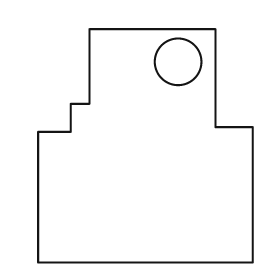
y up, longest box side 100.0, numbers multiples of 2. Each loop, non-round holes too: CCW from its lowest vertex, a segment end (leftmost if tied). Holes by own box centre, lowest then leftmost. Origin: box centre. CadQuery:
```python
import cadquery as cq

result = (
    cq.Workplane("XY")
    .moveTo(-46.0, -50.0)
    .lineTo(46.0, -50.0)
    .lineTo(46.0, 8.0)
    .lineTo(30.0, 8.0)
    .lineTo(30.0, 50.0)
    .lineTo(-24.0, 50.0)
    .lineTo(-24.0, 18.0)
    .lineTo(-32.0, 18.0)
    .lineTo(-32.0, 6.0)
    .lineTo(-46.0, 6.0)
    .close()
    .moveTo(14.0, 36.0)
    .circle(10.0)
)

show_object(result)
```